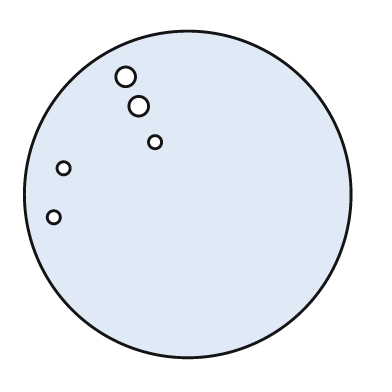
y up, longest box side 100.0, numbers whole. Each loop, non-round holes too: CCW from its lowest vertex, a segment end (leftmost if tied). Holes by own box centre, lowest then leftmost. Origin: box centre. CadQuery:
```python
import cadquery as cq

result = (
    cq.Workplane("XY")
    .moveTo(0.0, 0.0)
    .circle(50.0)
    .moveTo(-41.0, -7.0)
    .circle(2.0)
    .moveTo(-38.0, 8.0)
    .circle(2.0)
    .moveTo(-10.0, 16.0)
    .circle(2.0)
    .moveTo(-15.0, 27.0)
    .circle(3.0)
    .moveTo(-19.0, 36.0)
    .circle(3.0)
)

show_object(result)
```